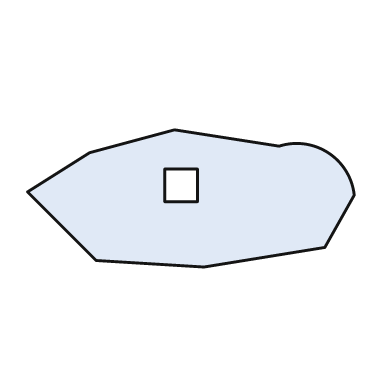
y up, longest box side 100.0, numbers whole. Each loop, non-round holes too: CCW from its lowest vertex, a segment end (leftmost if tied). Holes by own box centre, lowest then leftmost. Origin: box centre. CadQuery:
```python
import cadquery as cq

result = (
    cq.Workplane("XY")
    .moveTo(4.0, -21.0)
    .lineTo(41.0, -15.0)
    .lineTo(50.0, 1.0)
    .threePointArc((42.0, 14.0), (27.0, 16.0))
    .lineTo(-5.0, 21.0)
    .lineTo(-31.0, 14.0)
    .lineTo(-50.0, 2.0)
    .lineTo(-29.0, -19.0)
    .close()
    .moveTo(-8.0, -1.0)
    .lineTo(2.0, -1.0)
    .lineTo(2.0, 9.0)
    .lineTo(-8.0, 9.0)
    .close()
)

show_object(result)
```